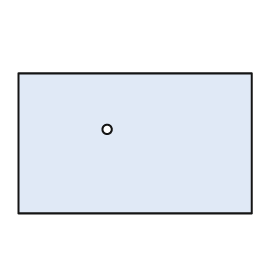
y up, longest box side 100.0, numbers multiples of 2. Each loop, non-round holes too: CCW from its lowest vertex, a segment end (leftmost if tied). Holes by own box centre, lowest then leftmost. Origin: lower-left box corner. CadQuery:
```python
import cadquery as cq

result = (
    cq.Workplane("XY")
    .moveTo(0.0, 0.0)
    .lineTo(100.0, 0.0)
    .lineTo(100.0, 60.0)
    .lineTo(0.0, 60.0)
    .close()
    .moveTo(38.0, 36.0)
    .circle(2.0)
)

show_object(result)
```